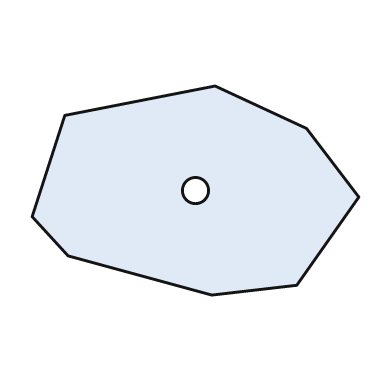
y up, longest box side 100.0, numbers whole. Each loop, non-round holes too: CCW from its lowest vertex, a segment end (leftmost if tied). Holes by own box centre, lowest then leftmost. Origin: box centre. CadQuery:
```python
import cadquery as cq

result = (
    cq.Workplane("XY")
    .moveTo(5.0, -32.0)
    .lineTo(31.0, -29.0)
    .lineTo(50.0, -2.0)
    .lineTo(34.0, 19.0)
    .lineTo(6.0, 32.0)
    .lineTo(-40.0, 23.0)
    .lineTo(-50.0, -8.0)
    .lineTo(-39.0, -20.0)
    .close()
    .moveTo(0.0, 0.0)
    .circle(4.0)
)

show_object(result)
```